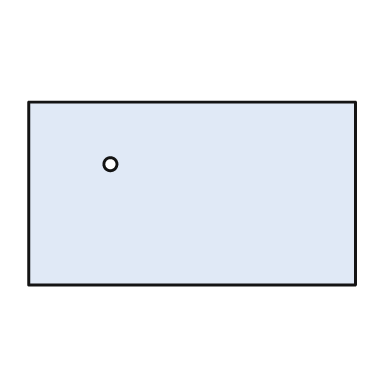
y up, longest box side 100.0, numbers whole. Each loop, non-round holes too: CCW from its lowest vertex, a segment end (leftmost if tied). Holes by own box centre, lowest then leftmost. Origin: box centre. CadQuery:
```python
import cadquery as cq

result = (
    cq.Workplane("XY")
    .moveTo(-50.0, -28.0)
    .lineTo(50.0, -28.0)
    .lineTo(50.0, 28.0)
    .lineTo(-50.0, 28.0)
    .close()
    .moveTo(-25.0, 9.0)
    .circle(2.0)
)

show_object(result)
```